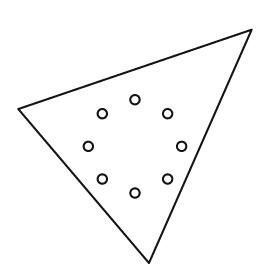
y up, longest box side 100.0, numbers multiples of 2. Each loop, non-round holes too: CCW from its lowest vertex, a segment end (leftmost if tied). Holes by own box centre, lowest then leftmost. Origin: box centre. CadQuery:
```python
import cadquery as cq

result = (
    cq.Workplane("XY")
    .moveTo(6.0, -50.0)
    .lineTo(50.0, 50.0)
    .lineTo(-50.0, 16.0)
    .close()
    .moveTo(0.0, -20.0)
    .circle(2.0)
    .moveTo(-14.0, -14.0)
    .circle(2.0)
    .moveTo(14.0, -14.0)
    .circle(2.0)
    .moveTo(-20.0, 0.0)
    .circle(2.0)
    .moveTo(20.0, 0.0)
    .circle(2.0)
    .moveTo(-14.0, 14.0)
    .circle(2.0)
    .moveTo(14.0, 14.0)
    .circle(2.0)
    .moveTo(0.0, 20.0)
    .circle(2.0)
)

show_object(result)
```